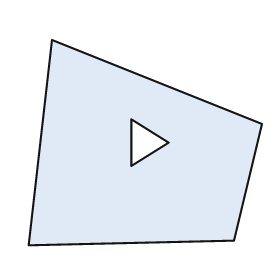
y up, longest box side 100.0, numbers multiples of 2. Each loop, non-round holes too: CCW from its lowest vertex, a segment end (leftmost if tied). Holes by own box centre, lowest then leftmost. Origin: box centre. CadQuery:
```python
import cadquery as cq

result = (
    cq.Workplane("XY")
    .moveTo(-50.0, -44.0)
    .lineTo(38.0, -42.0)
    .lineTo(50.0, 8.0)
    .lineTo(-40.0, 44.0)
    .close()
    .moveTo(-6.0, -10.0)
    .lineTo(10.0, 0.0)
    .lineTo(-6.0, 10.0)
    .close()
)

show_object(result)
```